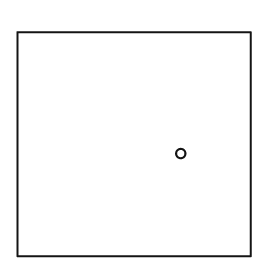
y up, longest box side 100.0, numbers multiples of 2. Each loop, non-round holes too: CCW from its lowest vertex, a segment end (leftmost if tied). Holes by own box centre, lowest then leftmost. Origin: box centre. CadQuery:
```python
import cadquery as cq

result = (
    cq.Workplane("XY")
    .moveTo(-50.0, -48.0)
    .lineTo(50.0, -48.0)
    .lineTo(50.0, 48.0)
    .lineTo(-50.0, 48.0)
    .close()
    .moveTo(20.0, -4.0)
    .circle(2.0)
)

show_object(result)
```